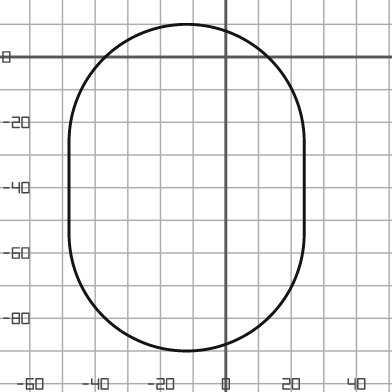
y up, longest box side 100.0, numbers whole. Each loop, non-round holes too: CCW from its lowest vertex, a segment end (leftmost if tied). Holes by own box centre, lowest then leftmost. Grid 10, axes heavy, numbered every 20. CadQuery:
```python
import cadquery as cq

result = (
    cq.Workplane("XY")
    .moveTo(-48.0, -54.0)
    .threePointArc((-12.0, -90.0), (24.0, -54.0))
    .lineTo(24.0, -26.0)
    .threePointArc((-12.0, 10.0), (-48.0, -26.0))
    .close()
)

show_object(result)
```